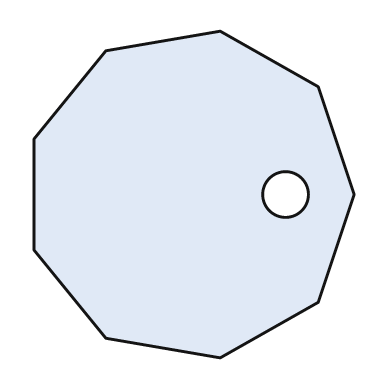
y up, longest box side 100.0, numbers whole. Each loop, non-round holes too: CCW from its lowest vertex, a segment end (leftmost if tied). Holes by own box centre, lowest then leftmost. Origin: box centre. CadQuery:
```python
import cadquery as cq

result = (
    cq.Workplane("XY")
    .moveTo(8.0, -50.0)
    .lineTo(38.0, -33.0)
    .lineTo(49.0, 0.0)
    .lineTo(38.0, 33.0)
    .lineTo(8.0, 50.0)
    .lineTo(-27.0, 44.0)
    .lineTo(-49.0, 17.0)
    .lineTo(-49.0, -17.0)
    .lineTo(-27.0, -44.0)
    .close()
    .moveTo(28.0, 0.0)
    .circle(7.0)
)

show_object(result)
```